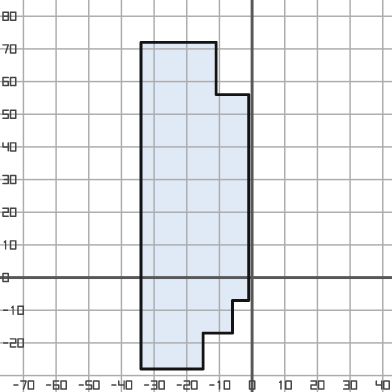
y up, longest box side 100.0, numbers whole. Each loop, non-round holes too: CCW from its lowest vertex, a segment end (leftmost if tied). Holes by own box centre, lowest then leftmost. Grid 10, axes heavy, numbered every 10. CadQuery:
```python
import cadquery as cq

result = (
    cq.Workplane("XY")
    .moveTo(-34.0, -28.0)
    .lineTo(-15.0, -28.0)
    .lineTo(-15.0, -17.0)
    .lineTo(-6.0, -17.0)
    .lineTo(-6.0, -7.0)
    .lineTo(-1.0, -7.0)
    .lineTo(-1.0, 56.0)
    .lineTo(-11.0, 56.0)
    .lineTo(-11.0, 72.0)
    .lineTo(-34.0, 72.0)
    .close()
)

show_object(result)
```